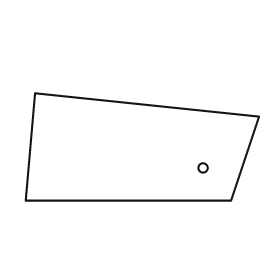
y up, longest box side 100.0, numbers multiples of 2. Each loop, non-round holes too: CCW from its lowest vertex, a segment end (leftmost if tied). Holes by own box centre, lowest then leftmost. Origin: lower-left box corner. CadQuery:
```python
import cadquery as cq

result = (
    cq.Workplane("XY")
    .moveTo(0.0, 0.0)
    .lineTo(88.0, 0.0)
    .lineTo(100.0, 36.0)
    .lineTo(4.0, 46.0)
    .close()
    .moveTo(76.0, 14.0)
    .circle(2.0)
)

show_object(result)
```